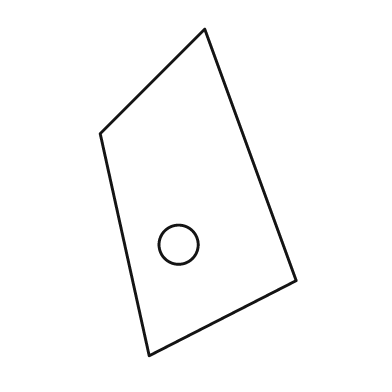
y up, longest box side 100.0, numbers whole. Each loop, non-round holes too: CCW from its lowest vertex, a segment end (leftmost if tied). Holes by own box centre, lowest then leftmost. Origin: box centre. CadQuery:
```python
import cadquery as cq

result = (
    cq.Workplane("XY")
    .moveTo(-15.0, -50.0)
    .lineTo(30.0, -27.0)
    .lineTo(2.0, 50.0)
    .lineTo(-30.0, 18.0)
    .close()
    .moveTo(-6.0, -16.0)
    .circle(6.0)
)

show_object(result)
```